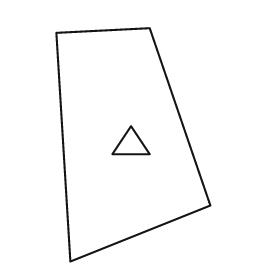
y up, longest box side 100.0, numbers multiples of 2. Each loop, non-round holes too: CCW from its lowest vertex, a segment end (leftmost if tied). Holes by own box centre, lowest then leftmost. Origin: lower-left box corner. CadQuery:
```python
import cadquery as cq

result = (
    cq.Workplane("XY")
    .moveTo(6.0, 0.0)
    .lineTo(66.0, 24.0)
    .lineTo(40.0, 100.0)
    .lineTo(0.0, 98.0)
    .close()
    .moveTo(24.0, 46.0)
    .lineTo(40.0, 46.0)
    .lineTo(32.0, 58.0)
    .close()
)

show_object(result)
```